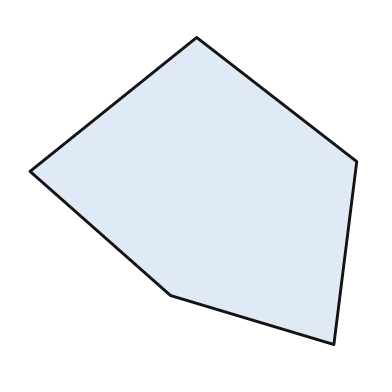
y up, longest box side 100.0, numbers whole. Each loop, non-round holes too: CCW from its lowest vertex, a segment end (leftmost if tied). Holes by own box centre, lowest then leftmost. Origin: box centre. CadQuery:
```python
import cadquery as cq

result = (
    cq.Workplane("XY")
    .moveTo(43.0, -47.0)
    .lineTo(50.0, 9.0)
    .lineTo(1.0, 47.0)
    .lineTo(-50.0, 6.0)
    .lineTo(-7.0, -32.0)
    .close()
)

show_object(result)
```